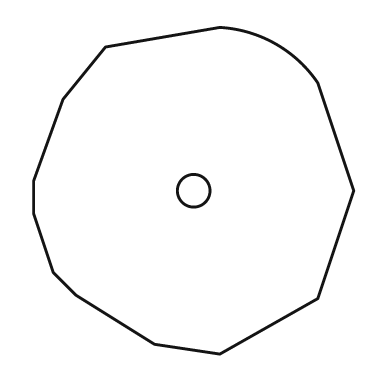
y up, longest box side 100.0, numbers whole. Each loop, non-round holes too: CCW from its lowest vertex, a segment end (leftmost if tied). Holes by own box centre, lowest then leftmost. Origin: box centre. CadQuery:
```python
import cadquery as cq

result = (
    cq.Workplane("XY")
    .moveTo(8.0, -50.0)
    .lineTo(38.0, -33.0)
    .lineTo(49.0, 0.0)
    .lineTo(38.0, 33.0)
    .threePointArc((25.0, 45.0), (8.0, 50.0))
    .lineTo(-27.0, 44.0)
    .lineTo(-40.0, 28.0)
    .lineTo(-49.0, 3.0)
    .lineTo(-49.0, -7.0)
    .lineTo(-43.0, -25.0)
    .lineTo(-36.0, -32.0)
    .lineTo(-12.0, -47.0)
    .close()
    .moveTo(0.0, 0.0)
    .circle(5.0)
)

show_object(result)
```